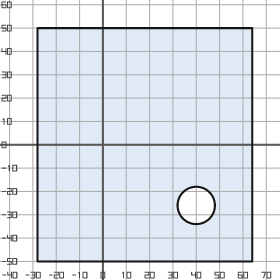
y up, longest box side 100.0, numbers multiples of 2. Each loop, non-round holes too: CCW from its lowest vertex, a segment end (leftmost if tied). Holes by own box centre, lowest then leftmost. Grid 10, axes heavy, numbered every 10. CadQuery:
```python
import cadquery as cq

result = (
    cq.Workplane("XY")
    .moveTo(-28.0, -50.0)
    .lineTo(64.0, -50.0)
    .lineTo(64.0, 50.0)
    .lineTo(-28.0, 50.0)
    .close()
    .moveTo(40.0, -26.0)
    .circle(8.0)
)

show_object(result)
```